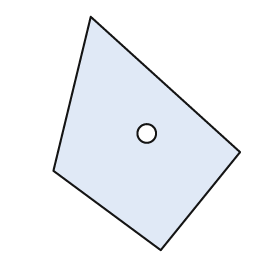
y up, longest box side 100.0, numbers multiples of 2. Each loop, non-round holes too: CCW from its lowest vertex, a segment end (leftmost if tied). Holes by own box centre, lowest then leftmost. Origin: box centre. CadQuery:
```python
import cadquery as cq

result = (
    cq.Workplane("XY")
    .moveTo(6.0, -50.0)
    .lineTo(40.0, -8.0)
    .lineTo(-24.0, 50.0)
    .lineTo(-40.0, -16.0)
    .close()
    .moveTo(0.0, 0.0)
    .circle(4.0)
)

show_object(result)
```